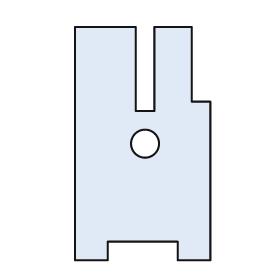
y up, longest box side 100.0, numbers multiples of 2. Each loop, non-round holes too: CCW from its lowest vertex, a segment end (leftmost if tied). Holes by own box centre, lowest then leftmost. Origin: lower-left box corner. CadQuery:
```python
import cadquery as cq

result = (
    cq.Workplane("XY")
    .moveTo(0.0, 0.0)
    .lineTo(14.0, 0.0)
    .lineTo(14.0, 8.0)
    .lineTo(44.0, 8.0)
    .lineTo(44.0, 0.0)
    .lineTo(58.0, 0.0)
    .lineTo(58.0, 68.0)
    .lineTo(50.0, 68.0)
    .lineTo(50.0, 100.0)
    .lineTo(34.0, 100.0)
    .lineTo(34.0, 64.0)
    .lineTo(26.0, 64.0)
    .lineTo(26.0, 100.0)
    .lineTo(0.0, 100.0)
    .close()
    .moveTo(30.0, 50.0)
    .circle(6.0)
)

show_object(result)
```